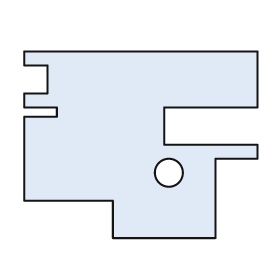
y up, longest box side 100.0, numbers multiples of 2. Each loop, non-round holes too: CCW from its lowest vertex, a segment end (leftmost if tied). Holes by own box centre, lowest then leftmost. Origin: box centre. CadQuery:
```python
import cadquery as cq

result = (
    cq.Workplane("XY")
    .moveTo(-12.0, -40.0)
    .lineTo(32.0, -40.0)
    .lineTo(32.0, -6.0)
    .lineTo(50.0, -6.0)
    .lineTo(50.0, 0.0)
    .lineTo(10.0, 0.0)
    .lineTo(10.0, 16.0)
    .lineTo(50.0, 16.0)
    .lineTo(50.0, 40.0)
    .lineTo(-50.0, 40.0)
    .lineTo(-50.0, 34.0)
    .lineTo(-40.0, 34.0)
    .lineTo(-40.0, 22.0)
    .lineTo(-50.0, 22.0)
    .lineTo(-50.0, 16.0)
    .lineTo(-36.0, 16.0)
    .lineTo(-36.0, 12.0)
    .lineTo(-50.0, 12.0)
    .lineTo(-50.0, -24.0)
    .lineTo(-12.0, -24.0)
    .close()
    .moveTo(12.0, -12.0)
    .circle(6.0)
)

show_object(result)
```